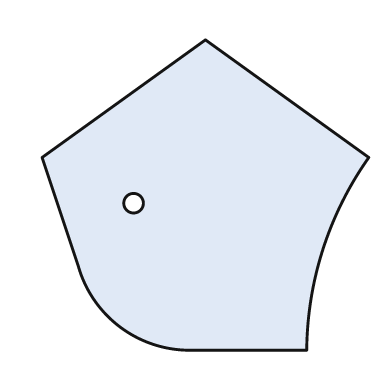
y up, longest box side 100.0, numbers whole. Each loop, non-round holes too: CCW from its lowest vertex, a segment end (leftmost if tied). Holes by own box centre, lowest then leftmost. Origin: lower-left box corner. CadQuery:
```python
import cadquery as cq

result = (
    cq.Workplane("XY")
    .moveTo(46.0, 0.0)
    .lineTo(81.0, 0.0)
    .threePointArc((86.0, 31.0), (100.0, 59.0))
    .lineTo(50.0, 95.0)
    .lineTo(0.0, 59.0)
    .lineTo(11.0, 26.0)
    .threePointArc((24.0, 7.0), (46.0, 0.0))
    .close()
    .moveTo(28.0, 45.0)
    .circle(3.0)
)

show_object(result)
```